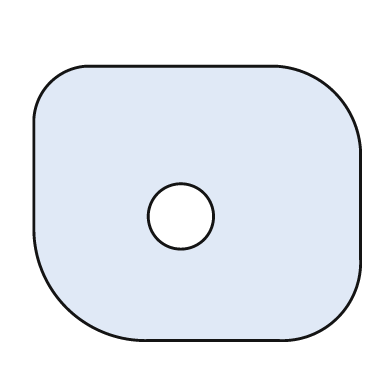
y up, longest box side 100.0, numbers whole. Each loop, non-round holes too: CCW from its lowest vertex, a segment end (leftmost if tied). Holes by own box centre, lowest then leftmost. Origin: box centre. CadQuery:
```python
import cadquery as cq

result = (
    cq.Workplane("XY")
    .moveTo(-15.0, -42.0)
    .lineTo(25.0, -42.0)
    .threePointArc((43.0, -35.0), (50.0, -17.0))
    .lineTo(50.0, 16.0)
    .threePointArc((42.0, 34.0), (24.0, 42.0))
    .lineTo(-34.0, 42.0)
    .threePointArc((-45.0, 37.0), (-50.0, 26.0))
    .lineTo(-50.0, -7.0)
    .threePointArc((-40.0, -32.0), (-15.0, -42.0))
    .close()
    .moveTo(-5.0, -4.0)
    .circle(10.0)
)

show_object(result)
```